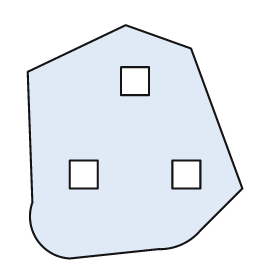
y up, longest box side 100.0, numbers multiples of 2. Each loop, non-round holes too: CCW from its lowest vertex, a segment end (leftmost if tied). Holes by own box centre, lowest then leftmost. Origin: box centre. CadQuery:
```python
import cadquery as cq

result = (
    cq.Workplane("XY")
    .moveTo(-28.0, -50.0)
    .lineTo(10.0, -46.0)
    .threePointArc((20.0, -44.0), (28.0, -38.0))
    .lineTo(46.0, -20.0)
    .lineTo(24.0, 40.0)
    .lineTo(-4.0, 50.0)
    .lineTo(-46.0, 30.0)
    .lineTo(-44.0, -26.0)
    .threePointArc((-42.0, -42.0), (-28.0, -50.0))
    .close()
    .moveTo(-28.0, -20.0)
    .lineTo(-16.0, -20.0)
    .lineTo(-16.0, -8.0)
    .lineTo(-28.0, -8.0)
    .close()
    .moveTo(16.0, -20.0)
    .lineTo(28.0, -20.0)
    .lineTo(28.0, -8.0)
    .lineTo(16.0, -8.0)
    .close()
    .moveTo(-6.0, 20.0)
    .lineTo(6.0, 20.0)
    .lineTo(6.0, 32.0)
    .lineTo(-6.0, 32.0)
    .close()
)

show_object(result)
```